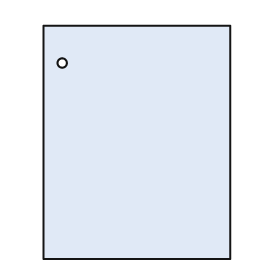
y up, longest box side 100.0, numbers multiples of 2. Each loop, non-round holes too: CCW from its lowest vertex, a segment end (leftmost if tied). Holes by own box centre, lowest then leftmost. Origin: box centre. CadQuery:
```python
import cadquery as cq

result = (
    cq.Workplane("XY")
    .moveTo(-40.0, -50.0)
    .lineTo(40.0, -50.0)
    .lineTo(40.0, 50.0)
    .lineTo(-40.0, 50.0)
    .close()
    .moveTo(-32.0, 34.0)
    .circle(2.0)
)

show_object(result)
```